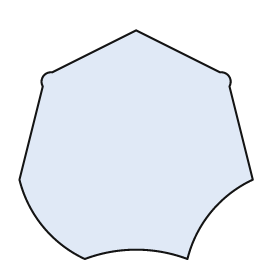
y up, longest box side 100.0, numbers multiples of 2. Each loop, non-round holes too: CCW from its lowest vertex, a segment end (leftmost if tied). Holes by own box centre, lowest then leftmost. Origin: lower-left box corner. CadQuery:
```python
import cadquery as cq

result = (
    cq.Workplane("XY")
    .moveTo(28.0, 0.0)
    .threePointArc((50.0, 4.0), (72.0, 0.0))
    .threePointArc((82.0, 20.0), (100.0, 34.0))
    .lineTo(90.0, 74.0)
    .threePointArc((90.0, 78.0), (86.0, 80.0))
    .lineTo(50.0, 98.0)
    .lineTo(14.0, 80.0)
    .threePointArc((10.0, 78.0), (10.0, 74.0))
    .lineTo(0.0, 34.0)
    .threePointArc((10.0, 14.0), (28.0, 0.0))
    .close()
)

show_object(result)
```